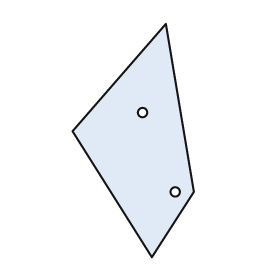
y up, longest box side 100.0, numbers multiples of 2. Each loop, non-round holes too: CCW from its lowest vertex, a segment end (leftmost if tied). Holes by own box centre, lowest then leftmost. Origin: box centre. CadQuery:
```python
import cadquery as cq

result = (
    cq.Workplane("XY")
    .moveTo(8.0, -50.0)
    .lineTo(26.0, -22.0)
    .lineTo(14.0, 50.0)
    .lineTo(-26.0, 4.0)
    .close()
    .moveTo(18.0, -22.0)
    .circle(2.0)
    .moveTo(4.0, 12.0)
    .circle(2.0)
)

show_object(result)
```